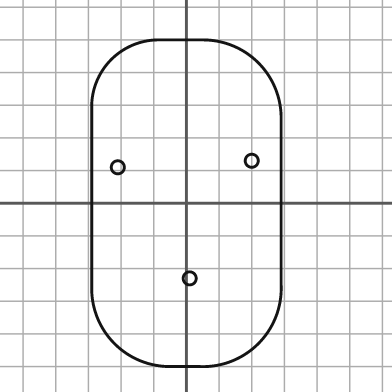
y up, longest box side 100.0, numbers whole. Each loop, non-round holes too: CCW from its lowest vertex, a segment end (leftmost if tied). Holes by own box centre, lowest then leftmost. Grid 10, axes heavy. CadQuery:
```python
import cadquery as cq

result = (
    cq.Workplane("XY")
    .moveTo(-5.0, -50.0)
    .lineTo(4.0, -50.0)
    .threePointArc((22.0, -43.0), (29.0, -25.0))
    .lineTo(29.0, 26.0)
    .threePointArc((22.0, 43.0), (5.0, 50.0))
    .lineTo(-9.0, 50.0)
    .threePointArc((-23.0, 44.0), (-29.0, 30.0))
    .lineTo(-29.0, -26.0)
    .threePointArc((-22.0, -43.0), (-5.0, -50.0))
    .close()
    .moveTo(1.0, -23.0)
    .circle(2.0)
    .moveTo(-21.0, 11.0)
    .circle(2.0)
    .moveTo(20.0, 13.0)
    .circle(2.0)
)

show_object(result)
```